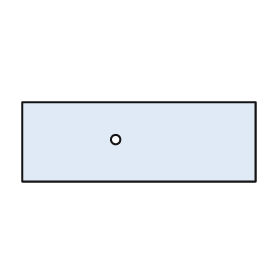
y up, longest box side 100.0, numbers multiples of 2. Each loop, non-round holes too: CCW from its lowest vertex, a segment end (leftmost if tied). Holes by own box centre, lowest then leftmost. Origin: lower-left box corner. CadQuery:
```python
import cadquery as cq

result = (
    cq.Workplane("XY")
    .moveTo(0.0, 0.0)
    .lineTo(100.0, 0.0)
    .lineTo(100.0, 34.0)
    .lineTo(0.0, 34.0)
    .close()
    .moveTo(40.0, 18.0)
    .circle(2.0)
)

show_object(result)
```